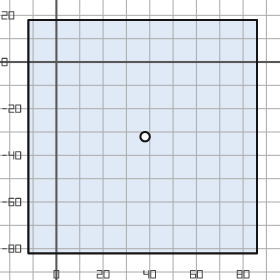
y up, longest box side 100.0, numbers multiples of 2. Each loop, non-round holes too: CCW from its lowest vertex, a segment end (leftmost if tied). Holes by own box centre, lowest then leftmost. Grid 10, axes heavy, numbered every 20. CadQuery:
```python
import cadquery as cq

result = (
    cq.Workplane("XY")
    .moveTo(-12.0, -82.0)
    .lineTo(86.0, -82.0)
    .lineTo(86.0, 18.0)
    .lineTo(-12.0, 18.0)
    .close()
    .moveTo(38.0, -32.0)
    .circle(2.0)
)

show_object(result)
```